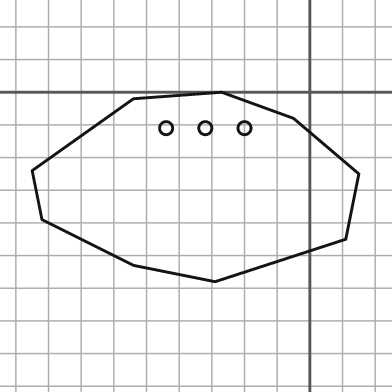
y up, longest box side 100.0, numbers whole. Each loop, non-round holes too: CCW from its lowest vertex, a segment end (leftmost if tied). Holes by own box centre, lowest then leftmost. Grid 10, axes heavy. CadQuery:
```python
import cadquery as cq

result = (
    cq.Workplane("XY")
    .moveTo(-29.0, -58.0)
    .lineTo(11.0, -45.0)
    .lineTo(15.0, -25.0)
    .lineTo(-5.0, -8.0)
    .lineTo(-27.0, 0.0)
    .lineTo(-54.0, -2.0)
    .lineTo(-85.0, -24.0)
    .lineTo(-82.0, -39.0)
    .lineTo(-54.0, -53.0)
    .close()
    .moveTo(-44.0, -11.0)
    .circle(2.0)
    .moveTo(-32.0, -11.0)
    .circle(2.0)
    .moveTo(-20.0, -11.0)
    .circle(2.0)
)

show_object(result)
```